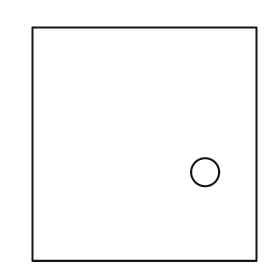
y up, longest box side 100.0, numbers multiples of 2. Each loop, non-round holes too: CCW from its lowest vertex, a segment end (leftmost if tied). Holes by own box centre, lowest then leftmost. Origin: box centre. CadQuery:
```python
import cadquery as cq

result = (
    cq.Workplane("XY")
    .moveTo(-48.0, -50.0)
    .lineTo(48.0, -50.0)
    .lineTo(48.0, 50.0)
    .lineTo(-48.0, 50.0)
    .close()
    .moveTo(26.0, -12.0)
    .circle(6.0)
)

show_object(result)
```